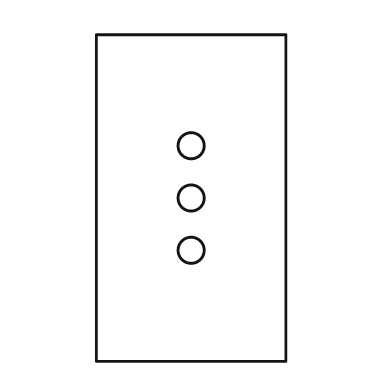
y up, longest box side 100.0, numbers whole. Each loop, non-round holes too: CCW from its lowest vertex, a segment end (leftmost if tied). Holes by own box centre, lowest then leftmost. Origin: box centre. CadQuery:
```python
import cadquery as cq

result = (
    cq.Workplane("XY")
    .moveTo(-29.0, -50.0)
    .lineTo(29.0, -50.0)
    .lineTo(29.0, 50.0)
    .lineTo(-29.0, 50.0)
    .close()
    .moveTo(0.0, -16.0)
    .circle(4.0)
    .moveTo(0.0, 0.0)
    .circle(4.0)
    .moveTo(0.0, 16.0)
    .circle(4.0)
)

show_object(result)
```